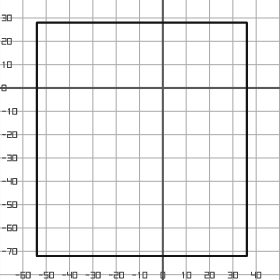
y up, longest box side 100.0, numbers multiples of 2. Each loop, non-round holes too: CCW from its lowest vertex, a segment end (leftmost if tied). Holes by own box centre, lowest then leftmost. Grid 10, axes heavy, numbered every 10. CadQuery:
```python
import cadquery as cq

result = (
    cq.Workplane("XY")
    .moveTo(-54.0, -72.0)
    .lineTo(36.0, -72.0)
    .lineTo(36.0, 28.0)
    .lineTo(-54.0, 28.0)
    .close()
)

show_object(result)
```